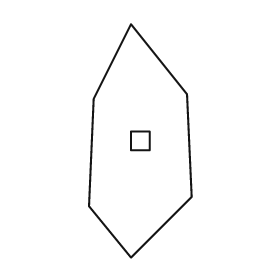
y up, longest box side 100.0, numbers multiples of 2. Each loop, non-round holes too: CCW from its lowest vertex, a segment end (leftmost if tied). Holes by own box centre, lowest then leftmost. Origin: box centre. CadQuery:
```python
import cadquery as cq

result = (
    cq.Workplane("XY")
    .moveTo(-4.0, -50.0)
    .lineTo(22.0, -24.0)
    .lineTo(20.0, 20.0)
    .lineTo(-4.0, 50.0)
    .lineTo(-20.0, 18.0)
    .lineTo(-22.0, -28.0)
    .close()
    .moveTo(-4.0, -4.0)
    .lineTo(4.0, -4.0)
    .lineTo(4.0, 4.0)
    .lineTo(-4.0, 4.0)
    .close()
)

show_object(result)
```